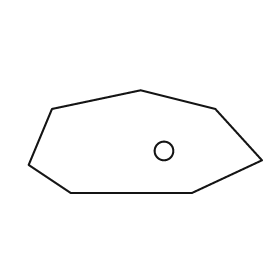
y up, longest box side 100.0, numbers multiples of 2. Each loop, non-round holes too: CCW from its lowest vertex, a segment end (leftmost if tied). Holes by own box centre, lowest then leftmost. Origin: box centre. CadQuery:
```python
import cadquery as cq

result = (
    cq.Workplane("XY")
    .moveTo(-32.0, -22.0)
    .lineTo(20.0, -22.0)
    .lineTo(50.0, -8.0)
    .lineTo(30.0, 14.0)
    .lineTo(-2.0, 22.0)
    .lineTo(-40.0, 14.0)
    .lineTo(-50.0, -10.0)
    .close()
    .moveTo(8.0, -4.0)
    .circle(4.0)
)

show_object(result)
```